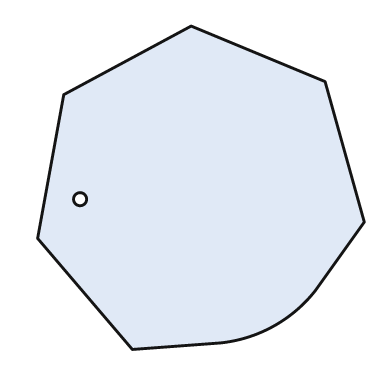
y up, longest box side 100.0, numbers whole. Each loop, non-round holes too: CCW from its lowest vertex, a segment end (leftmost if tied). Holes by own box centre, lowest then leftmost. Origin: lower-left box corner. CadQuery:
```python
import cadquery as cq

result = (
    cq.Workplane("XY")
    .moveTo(29.0, 0.0)
    .lineTo(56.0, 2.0)
    .threePointArc((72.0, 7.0), (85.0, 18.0))
    .lineTo(100.0, 39.0)
    .lineTo(88.0, 82.0)
    .lineTo(47.0, 99.0)
    .lineTo(8.0, 78.0)
    .lineTo(0.0, 34.0)
    .close()
    .moveTo(13.0, 46.0)
    .circle(2.0)
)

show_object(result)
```